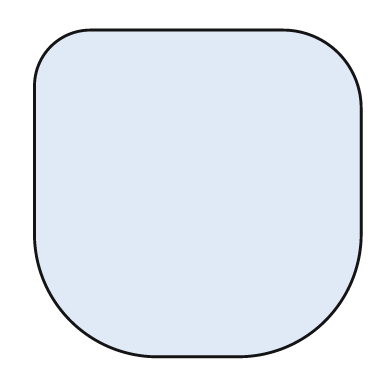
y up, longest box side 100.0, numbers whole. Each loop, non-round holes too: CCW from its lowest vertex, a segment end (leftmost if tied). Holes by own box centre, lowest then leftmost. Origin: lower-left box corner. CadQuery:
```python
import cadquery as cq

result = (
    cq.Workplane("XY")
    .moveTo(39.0, 0.0)
    .lineTo(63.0, 0.0)
    .threePointArc((89.0, 11.0), (100.0, 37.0))
    .lineTo(100.0, 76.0)
    .threePointArc((93.0, 93.0), (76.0, 100.0))
    .lineTo(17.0, 100.0)
    .threePointArc((5.0, 95.0), (0.0, 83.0))
    .lineTo(0.0, 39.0)
    .threePointArc((11.0, 11.0), (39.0, 0.0))
    .close()
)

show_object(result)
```